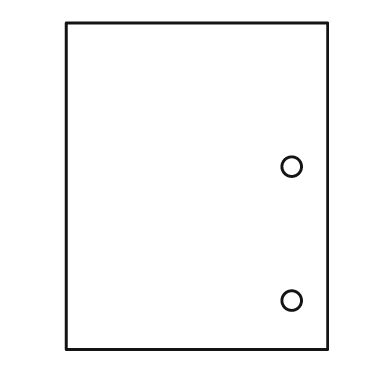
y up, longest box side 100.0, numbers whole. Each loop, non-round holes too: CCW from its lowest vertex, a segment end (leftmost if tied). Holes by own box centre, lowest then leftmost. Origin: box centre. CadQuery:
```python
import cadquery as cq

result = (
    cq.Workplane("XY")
    .moveTo(-40.0, -50.0)
    .lineTo(40.0, -50.0)
    .lineTo(40.0, 50.0)
    .lineTo(-40.0, 50.0)
    .close()
    .moveTo(29.0, -35.0)
    .circle(3.0)
    .moveTo(29.0, 6.0)
    .circle(3.0)
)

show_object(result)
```